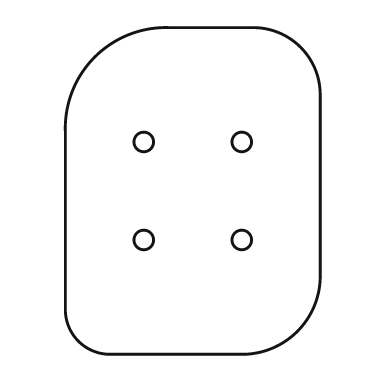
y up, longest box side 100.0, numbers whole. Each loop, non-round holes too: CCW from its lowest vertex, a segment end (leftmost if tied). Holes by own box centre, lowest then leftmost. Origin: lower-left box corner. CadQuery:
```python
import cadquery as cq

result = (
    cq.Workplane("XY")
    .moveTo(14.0, 0.0)
    .lineTo(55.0, 0.0)
    .threePointArc((71.0, 7.0), (78.0, 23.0))
    .lineTo(78.0, 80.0)
    .threePointArc((72.0, 94.0), (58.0, 100.0))
    .lineTo(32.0, 100.0)
    .threePointArc((9.0, 91.0), (0.0, 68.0))
    .lineTo(0.0, 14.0)
    .threePointArc((4.0, 4.0), (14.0, 0.0))
    .close()
    .moveTo(24.0, 35.0)
    .circle(3.0)
    .moveTo(54.0, 35.0)
    .circle(3.0)
    .moveTo(24.0, 65.0)
    .circle(3.0)
    .moveTo(54.0, 65.0)
    .circle(3.0)
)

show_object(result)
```